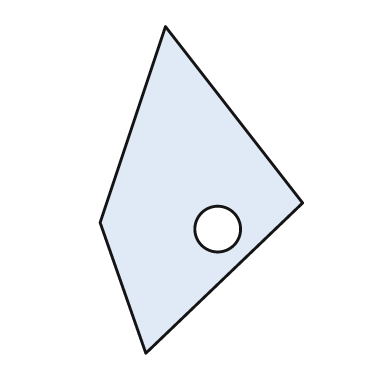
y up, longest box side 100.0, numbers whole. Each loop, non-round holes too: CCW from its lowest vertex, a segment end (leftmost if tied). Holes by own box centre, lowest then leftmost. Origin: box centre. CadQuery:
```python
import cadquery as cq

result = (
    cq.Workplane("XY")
    .moveTo(-17.0, -50.0)
    .lineTo(31.0, -4.0)
    .lineTo(-11.0, 50.0)
    .lineTo(-31.0, -10.0)
    .close()
    .moveTo(5.0, -12.0)
    .circle(7.0)
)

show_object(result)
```